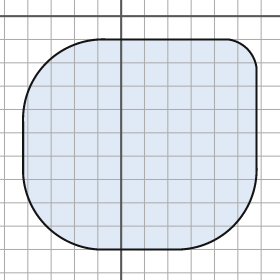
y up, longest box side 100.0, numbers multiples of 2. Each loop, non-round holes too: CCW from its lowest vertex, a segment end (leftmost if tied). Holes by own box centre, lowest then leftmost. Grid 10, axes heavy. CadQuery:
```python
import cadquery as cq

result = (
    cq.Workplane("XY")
    .moveTo(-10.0, -100.0)
    .lineTo(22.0, -100.0)
    .threePointArc((48.0, -90.0), (58.0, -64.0))
    .lineTo(58.0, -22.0)
    .threePointArc((54.0, -14.0), (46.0, -10.0))
    .lineTo(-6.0, -10.0)
    .threePointArc((-32.0, -20.0), (-42.0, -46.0))
    .lineTo(-42.0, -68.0)
    .threePointArc((-32.0, -90.0), (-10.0, -100.0))
    .close()
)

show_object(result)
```